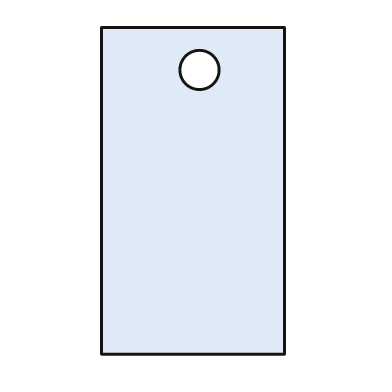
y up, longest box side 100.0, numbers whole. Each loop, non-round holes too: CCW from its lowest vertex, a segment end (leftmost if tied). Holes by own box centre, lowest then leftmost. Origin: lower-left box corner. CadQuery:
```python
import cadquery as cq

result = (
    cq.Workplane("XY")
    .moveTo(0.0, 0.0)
    .lineTo(56.0, 0.0)
    .lineTo(56.0, 100.0)
    .lineTo(0.0, 100.0)
    .close()
    .moveTo(30.0, 87.0)
    .circle(6.0)
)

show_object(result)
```